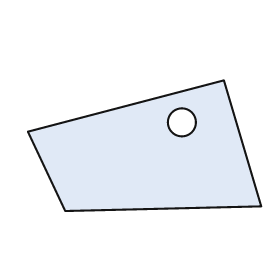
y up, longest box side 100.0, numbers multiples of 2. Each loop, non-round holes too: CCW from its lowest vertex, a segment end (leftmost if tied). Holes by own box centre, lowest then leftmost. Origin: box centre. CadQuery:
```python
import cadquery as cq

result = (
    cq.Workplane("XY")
    .moveTo(-34.0, -28.0)
    .lineTo(50.0, -26.0)
    .lineTo(34.0, 28.0)
    .lineTo(-50.0, 6.0)
    .close()
    .moveTo(16.0, 10.0)
    .circle(6.0)
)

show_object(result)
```